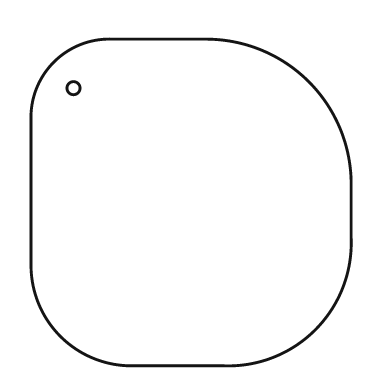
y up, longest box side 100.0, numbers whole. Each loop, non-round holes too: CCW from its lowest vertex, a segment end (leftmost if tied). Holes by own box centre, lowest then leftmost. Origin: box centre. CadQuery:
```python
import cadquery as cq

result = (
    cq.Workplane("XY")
    .moveTo(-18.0, -50.0)
    .lineTo(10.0, -50.0)
    .threePointArc((38.0, -39.0), (49.0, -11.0))
    .lineTo(49.0, 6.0)
    .threePointArc((36.0, 37.0), (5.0, 50.0))
    .lineTo(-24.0, 50.0)
    .threePointArc((-42.0, 43.0), (-49.0, 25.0))
    .lineTo(-49.0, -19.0)
    .threePointArc((-40.0, -41.0), (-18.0, -50.0))
    .close()
    .moveTo(-36.0, 35.0)
    .circle(2.0)
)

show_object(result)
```